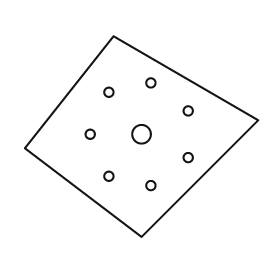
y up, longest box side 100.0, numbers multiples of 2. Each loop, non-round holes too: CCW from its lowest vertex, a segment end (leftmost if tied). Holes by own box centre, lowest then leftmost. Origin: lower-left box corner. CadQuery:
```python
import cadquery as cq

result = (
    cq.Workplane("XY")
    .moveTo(50.0, 0.0)
    .lineTo(100.0, 50.0)
    .lineTo(38.0, 86.0)
    .lineTo(0.0, 38.0)
    .close()
    .moveTo(54.0, 22.0)
    .circle(2.0)
    .moveTo(36.0, 26.0)
    .circle(2.0)
    .moveTo(70.0, 34.0)
    .circle(2.0)
    .moveTo(28.0, 44.0)
    .circle(2.0)
    .moveTo(50.0, 44.0)
    .circle(4.0)
    .moveTo(70.0, 54.0)
    .circle(2.0)
    .moveTo(36.0, 62.0)
    .circle(2.0)
    .moveTo(54.0, 66.0)
    .circle(2.0)
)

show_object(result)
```